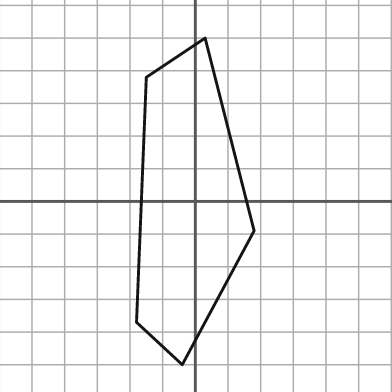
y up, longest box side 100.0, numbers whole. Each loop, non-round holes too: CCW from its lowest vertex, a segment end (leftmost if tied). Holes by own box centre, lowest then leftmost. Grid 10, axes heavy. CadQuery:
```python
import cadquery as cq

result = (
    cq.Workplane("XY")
    .moveTo(-4.0, -50.0)
    .lineTo(18.0, -9.0)
    .lineTo(3.0, 50.0)
    .lineTo(-15.0, 38.0)
    .lineTo(-18.0, -37.0)
    .close()
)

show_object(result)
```